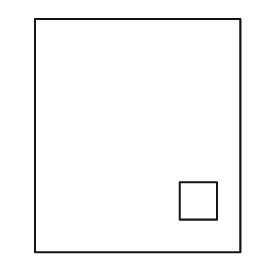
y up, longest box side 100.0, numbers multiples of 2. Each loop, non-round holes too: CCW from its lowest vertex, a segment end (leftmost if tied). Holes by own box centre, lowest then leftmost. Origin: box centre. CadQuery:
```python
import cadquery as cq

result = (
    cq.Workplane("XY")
    .moveTo(-44.0, -50.0)
    .lineTo(44.0, -50.0)
    .lineTo(44.0, 50.0)
    .lineTo(-44.0, 50.0)
    .close()
    .moveTo(18.0, -36.0)
    .lineTo(34.0, -36.0)
    .lineTo(34.0, -20.0)
    .lineTo(18.0, -20.0)
    .close()
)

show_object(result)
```